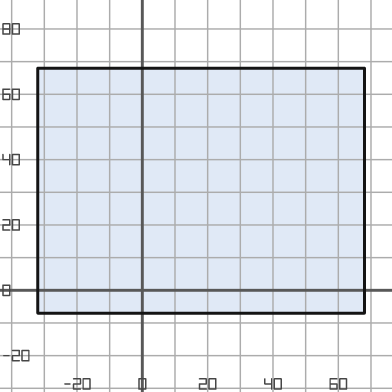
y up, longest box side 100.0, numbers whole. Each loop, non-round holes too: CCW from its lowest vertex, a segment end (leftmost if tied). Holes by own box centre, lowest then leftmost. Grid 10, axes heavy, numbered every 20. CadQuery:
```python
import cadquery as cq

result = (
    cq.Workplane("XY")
    .moveTo(-32.0, -7.0)
    .lineTo(68.0, -7.0)
    .lineTo(68.0, 68.0)
    .lineTo(-32.0, 68.0)
    .close()
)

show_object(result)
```